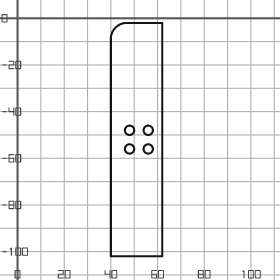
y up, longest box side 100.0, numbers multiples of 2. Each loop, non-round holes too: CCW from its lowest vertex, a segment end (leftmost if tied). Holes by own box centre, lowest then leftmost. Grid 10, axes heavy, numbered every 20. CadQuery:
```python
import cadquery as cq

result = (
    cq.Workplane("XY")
    .moveTo(40.0, -102.0)
    .lineTo(62.0, -102.0)
    .lineTo(62.0, -2.0)
    .lineTo(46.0, -2.0)
    .threePointArc((42.0, -4.0), (40.0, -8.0))
    .close()
    .moveTo(48.0, -56.0)
    .circle(2.0)
    .moveTo(56.0, -56.0)
    .circle(2.0)
    .moveTo(48.0, -48.0)
    .circle(2.0)
    .moveTo(56.0, -48.0)
    .circle(2.0)
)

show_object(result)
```